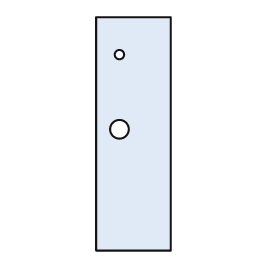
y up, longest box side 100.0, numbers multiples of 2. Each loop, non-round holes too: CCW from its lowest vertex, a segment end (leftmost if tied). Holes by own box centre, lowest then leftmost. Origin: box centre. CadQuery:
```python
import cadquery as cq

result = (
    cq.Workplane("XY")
    .moveTo(-16.0, -50.0)
    .lineTo(16.0, -50.0)
    .lineTo(16.0, 50.0)
    .lineTo(-16.0, 50.0)
    .close()
    .moveTo(-6.0, 2.0)
    .circle(4.0)
    .moveTo(-6.0, 34.0)
    .circle(2.0)
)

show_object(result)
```